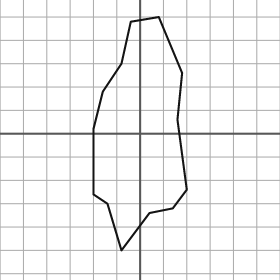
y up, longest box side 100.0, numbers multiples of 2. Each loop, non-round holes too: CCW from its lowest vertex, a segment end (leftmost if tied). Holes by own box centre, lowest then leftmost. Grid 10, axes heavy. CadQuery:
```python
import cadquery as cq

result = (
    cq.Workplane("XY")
    .moveTo(-8.0, -50.0)
    .lineTo(4.0, -34.0)
    .lineTo(14.0, -32.0)
    .lineTo(20.0, -24.0)
    .lineTo(16.0, 6.0)
    .lineTo(18.0, 26.0)
    .lineTo(8.0, 50.0)
    .lineTo(-4.0, 48.0)
    .lineTo(-8.0, 30.0)
    .lineTo(-16.0, 18.0)
    .lineTo(-20.0, 2.0)
    .lineTo(-20.0, -26.0)
    .lineTo(-14.0, -30.0)
    .close()
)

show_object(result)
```